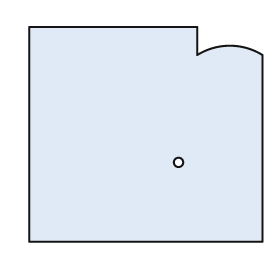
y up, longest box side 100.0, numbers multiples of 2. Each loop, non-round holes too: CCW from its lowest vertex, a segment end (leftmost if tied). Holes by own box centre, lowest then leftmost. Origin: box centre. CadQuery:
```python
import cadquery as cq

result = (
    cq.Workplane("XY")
    .moveTo(-50.0, -46.0)
    .lineTo(50.0, -46.0)
    .lineTo(50.0, 34.0)
    .threePointArc((36.0, 38.0), (22.0, 34.0))
    .lineTo(22.0, 46.0)
    .lineTo(-50.0, 46.0)
    .close()
    .moveTo(14.0, -12.0)
    .circle(2.0)
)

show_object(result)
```